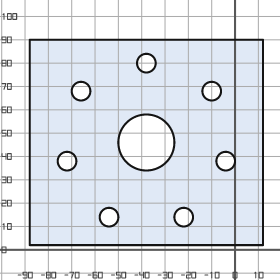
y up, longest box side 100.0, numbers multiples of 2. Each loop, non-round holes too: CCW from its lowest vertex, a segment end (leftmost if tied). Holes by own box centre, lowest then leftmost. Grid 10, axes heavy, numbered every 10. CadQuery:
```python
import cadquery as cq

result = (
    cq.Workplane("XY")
    .moveTo(-88.0, 2.0)
    .lineTo(12.0, 2.0)
    .lineTo(12.0, 90.0)
    .lineTo(-88.0, 90.0)
    .close()
    .moveTo(-54.0, 14.0)
    .circle(4.0)
    .moveTo(-22.0, 14.0)
    .circle(4.0)
    .moveTo(-72.0, 38.0)
    .circle(4.0)
    .moveTo(-4.0, 38.0)
    .circle(4.0)
    .moveTo(-38.0, 46.0)
    .circle(12.0)
    .moveTo(-66.0, 68.0)
    .circle(4.0)
    .moveTo(-10.0, 68.0)
    .circle(4.0)
    .moveTo(-38.0, 80.0)
    .circle(4.0)
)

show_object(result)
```